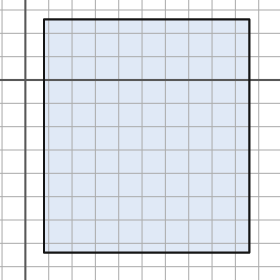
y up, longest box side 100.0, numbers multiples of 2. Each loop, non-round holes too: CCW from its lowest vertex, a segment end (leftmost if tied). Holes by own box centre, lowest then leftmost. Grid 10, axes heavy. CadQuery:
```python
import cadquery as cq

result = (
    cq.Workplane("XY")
    .moveTo(8.0, -74.0)
    .lineTo(96.0, -74.0)
    .lineTo(96.0, 26.0)
    .lineTo(8.0, 26.0)
    .close()
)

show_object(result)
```